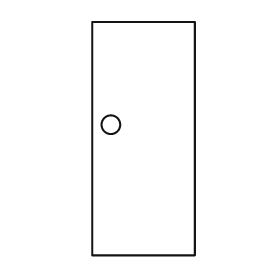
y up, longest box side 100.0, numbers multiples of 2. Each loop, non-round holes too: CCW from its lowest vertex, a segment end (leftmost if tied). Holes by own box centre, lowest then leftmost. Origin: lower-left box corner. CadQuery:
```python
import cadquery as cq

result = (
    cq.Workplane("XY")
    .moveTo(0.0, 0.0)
    .lineTo(44.0, 0.0)
    .lineTo(44.0, 100.0)
    .lineTo(0.0, 100.0)
    .close()
    .moveTo(8.0, 56.0)
    .circle(4.0)
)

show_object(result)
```